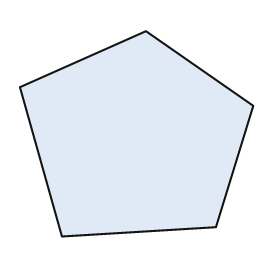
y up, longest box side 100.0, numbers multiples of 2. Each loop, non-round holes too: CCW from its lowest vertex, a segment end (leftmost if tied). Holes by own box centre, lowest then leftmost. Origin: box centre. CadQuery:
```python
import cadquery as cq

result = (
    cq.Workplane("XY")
    .moveTo(-32.0, -44.0)
    .lineTo(34.0, -40.0)
    .lineTo(50.0, 12.0)
    .lineTo(4.0, 44.0)
    .lineTo(-50.0, 20.0)
    .close()
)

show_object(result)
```